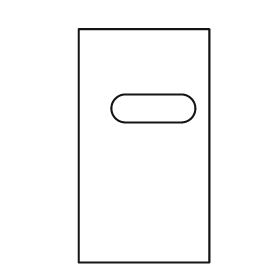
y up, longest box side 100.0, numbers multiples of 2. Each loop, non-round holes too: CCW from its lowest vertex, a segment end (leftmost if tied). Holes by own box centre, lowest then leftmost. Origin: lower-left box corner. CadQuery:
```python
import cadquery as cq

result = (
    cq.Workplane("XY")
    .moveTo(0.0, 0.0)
    .lineTo(56.0, 0.0)
    .lineTo(56.0, 100.0)
    .lineTo(0.0, 100.0)
    .close()
    .moveTo(20.0, 60.0)
    .lineTo(44.0, 60.0)
    .threePointArc((50.0, 66.0), (44.0, 72.0))
    .lineTo(20.0, 72.0)
    .threePointArc((14.0, 66.0), (20.0, 60.0))
    .close()
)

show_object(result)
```